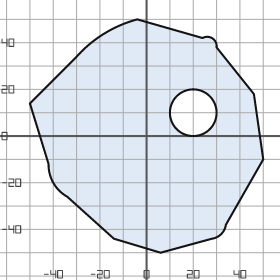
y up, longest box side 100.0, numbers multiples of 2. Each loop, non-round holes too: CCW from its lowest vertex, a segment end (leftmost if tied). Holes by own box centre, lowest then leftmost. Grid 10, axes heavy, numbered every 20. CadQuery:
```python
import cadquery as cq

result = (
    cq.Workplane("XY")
    .moveTo(6.0, -50.0)
    .lineTo(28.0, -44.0)
    .threePointArc((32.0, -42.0), (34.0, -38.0))
    .lineTo(50.0, -10.0)
    .lineTo(46.0, 18.0)
    .lineTo(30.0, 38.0)
    .threePointArc((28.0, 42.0), (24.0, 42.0))
    .lineTo(-4.0, 50.0)
    .threePointArc((-18.0, 44.0), (-30.0, 34.0))
    .lineTo(-50.0, 14.0)
    .lineTo(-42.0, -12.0)
    .threePointArc((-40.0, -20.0), (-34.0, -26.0))
    .lineTo(-14.0, -44.0)
    .close()
    .moveTo(20.0, 10.0)
    .circle(10.0)
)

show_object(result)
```